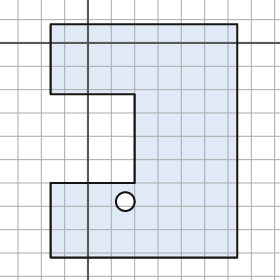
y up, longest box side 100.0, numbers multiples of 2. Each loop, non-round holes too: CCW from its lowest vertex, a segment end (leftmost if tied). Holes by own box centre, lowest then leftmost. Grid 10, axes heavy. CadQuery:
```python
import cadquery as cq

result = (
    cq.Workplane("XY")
    .moveTo(-16.0, -92.0)
    .lineTo(64.0, -92.0)
    .lineTo(64.0, 8.0)
    .lineTo(-16.0, 8.0)
    .lineTo(-16.0, -22.0)
    .lineTo(20.0, -22.0)
    .lineTo(20.0, -60.0)
    .lineTo(-16.0, -60.0)
    .close()
    .moveTo(16.0, -68.0)
    .circle(4.0)
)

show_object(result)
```